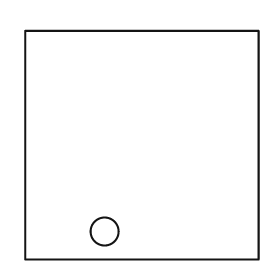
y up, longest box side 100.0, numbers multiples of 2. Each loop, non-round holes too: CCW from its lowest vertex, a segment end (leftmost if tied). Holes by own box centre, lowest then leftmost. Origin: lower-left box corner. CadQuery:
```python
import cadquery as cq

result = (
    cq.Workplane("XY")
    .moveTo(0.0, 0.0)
    .lineTo(100.0, 0.0)
    .lineTo(100.0, 98.0)
    .lineTo(0.0, 98.0)
    .close()
    .moveTo(34.0, 12.0)
    .circle(6.0)
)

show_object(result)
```